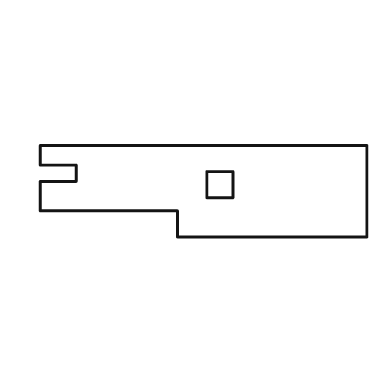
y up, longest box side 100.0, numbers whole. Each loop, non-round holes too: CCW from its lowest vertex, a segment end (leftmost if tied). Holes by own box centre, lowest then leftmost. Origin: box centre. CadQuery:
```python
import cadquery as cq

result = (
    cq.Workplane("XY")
    .moveTo(-8.0, -14.0)
    .lineTo(50.0, -14.0)
    .lineTo(50.0, 14.0)
    .lineTo(-50.0, 14.0)
    .lineTo(-50.0, 8.0)
    .lineTo(-39.0, 8.0)
    .lineTo(-39.0, 3.0)
    .lineTo(-50.0, 3.0)
    .lineTo(-50.0, -6.0)
    .lineTo(-8.0, -6.0)
    .close()
    .moveTo(1.0, -2.0)
    .lineTo(9.0, -2.0)
    .lineTo(9.0, 6.0)
    .lineTo(1.0, 6.0)
    .close()
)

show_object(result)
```